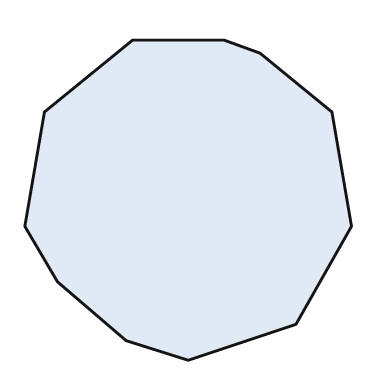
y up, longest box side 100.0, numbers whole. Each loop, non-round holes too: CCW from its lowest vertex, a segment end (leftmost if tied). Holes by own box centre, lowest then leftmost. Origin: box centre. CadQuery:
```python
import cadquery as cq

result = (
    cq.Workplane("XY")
    .moveTo(0.0, -49.0)
    .lineTo(33.0, -38.0)
    .lineTo(50.0, -8.0)
    .lineTo(44.0, 27.0)
    .lineTo(22.0, 45.0)
    .lineTo(11.0, 49.0)
    .lineTo(-17.0, 49.0)
    .lineTo(-44.0, 27.0)
    .lineTo(-50.0, -8.0)
    .lineTo(-40.0, -25.0)
    .lineTo(-19.0, -43.0)
    .close()
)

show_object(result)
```